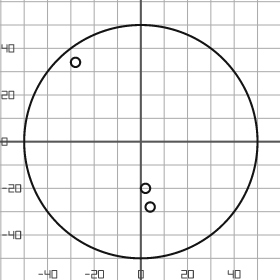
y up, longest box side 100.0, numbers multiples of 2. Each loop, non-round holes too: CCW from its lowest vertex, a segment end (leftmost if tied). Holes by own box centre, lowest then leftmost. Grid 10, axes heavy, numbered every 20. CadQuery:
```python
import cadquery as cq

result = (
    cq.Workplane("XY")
    .moveTo(0.0, 0.0)
    .circle(50.0)
    .moveTo(4.0, -28.0)
    .circle(2.0)
    .moveTo(2.0, -20.0)
    .circle(2.0)
    .moveTo(-28.0, 34.0)
    .circle(2.0)
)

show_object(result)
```